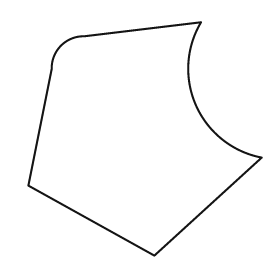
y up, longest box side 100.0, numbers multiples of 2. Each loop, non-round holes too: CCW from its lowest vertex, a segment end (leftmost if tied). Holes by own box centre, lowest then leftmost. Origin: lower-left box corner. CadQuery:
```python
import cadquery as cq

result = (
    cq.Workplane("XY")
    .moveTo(54.0, 0.0)
    .lineTo(100.0, 42.0)
    .threePointArc((72.0, 64.0), (74.0, 100.0))
    .lineTo(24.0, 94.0)
    .threePointArc((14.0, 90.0), (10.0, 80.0))
    .lineTo(0.0, 30.0)
    .close()
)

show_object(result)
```